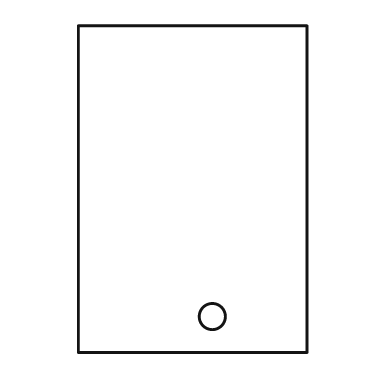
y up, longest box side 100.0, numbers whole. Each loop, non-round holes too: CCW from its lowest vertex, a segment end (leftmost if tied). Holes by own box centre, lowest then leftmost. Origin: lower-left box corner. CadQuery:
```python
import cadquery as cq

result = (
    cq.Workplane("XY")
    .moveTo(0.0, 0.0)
    .lineTo(70.0, 0.0)
    .lineTo(70.0, 100.0)
    .lineTo(0.0, 100.0)
    .close()
    .moveTo(41.0, 11.0)
    .circle(4.0)
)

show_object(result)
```